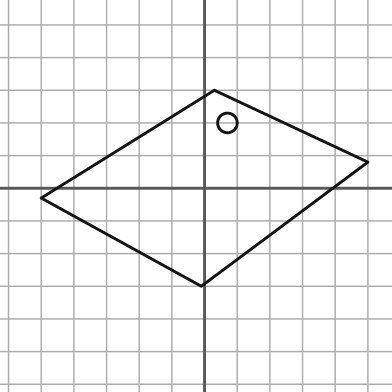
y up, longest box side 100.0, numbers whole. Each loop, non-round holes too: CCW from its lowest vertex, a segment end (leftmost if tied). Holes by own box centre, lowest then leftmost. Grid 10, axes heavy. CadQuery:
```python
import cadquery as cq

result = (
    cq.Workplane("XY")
    .moveTo(-1.0, -30.0)
    .lineTo(50.0, 8.0)
    .lineTo(3.0, 30.0)
    .lineTo(-50.0, -3.0)
    .close()
    .moveTo(7.0, 20.0)
    .circle(3.0)
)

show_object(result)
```